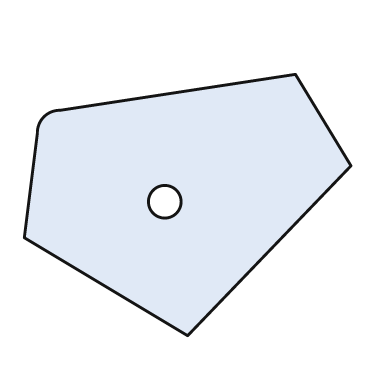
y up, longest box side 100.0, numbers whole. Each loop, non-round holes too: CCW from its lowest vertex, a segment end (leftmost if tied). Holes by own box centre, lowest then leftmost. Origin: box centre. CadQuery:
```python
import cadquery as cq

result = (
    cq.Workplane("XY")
    .moveTo(0.0, -40.0)
    .lineTo(50.0, 12.0)
    .lineTo(33.0, 40.0)
    .lineTo(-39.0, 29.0)
    .threePointArc((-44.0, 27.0), (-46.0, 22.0))
    .lineTo(-50.0, -10.0)
    .close()
    .moveTo(-7.0, 1.0)
    .circle(5.0)
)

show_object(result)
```